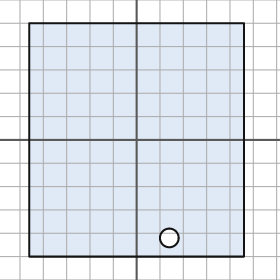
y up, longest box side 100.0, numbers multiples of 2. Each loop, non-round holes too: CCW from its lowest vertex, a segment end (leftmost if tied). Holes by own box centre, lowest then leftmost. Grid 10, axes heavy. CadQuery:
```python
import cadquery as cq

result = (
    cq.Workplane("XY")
    .moveTo(-46.0, -50.0)
    .lineTo(46.0, -50.0)
    .lineTo(46.0, 50.0)
    .lineTo(-46.0, 50.0)
    .close()
    .moveTo(14.0, -42.0)
    .circle(4.0)
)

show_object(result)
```